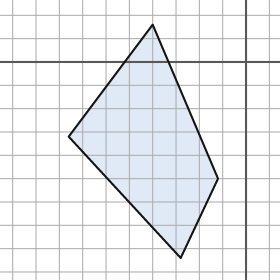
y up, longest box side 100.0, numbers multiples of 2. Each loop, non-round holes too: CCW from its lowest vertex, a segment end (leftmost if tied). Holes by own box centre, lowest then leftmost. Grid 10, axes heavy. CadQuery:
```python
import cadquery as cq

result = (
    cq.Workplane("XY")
    .moveTo(-28.0, -84.0)
    .lineTo(-12.0, -50.0)
    .lineTo(-40.0, 16.0)
    .lineTo(-76.0, -32.0)
    .close()
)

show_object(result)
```